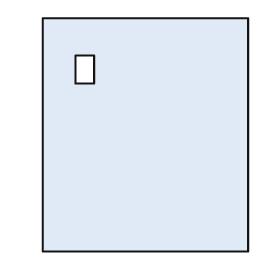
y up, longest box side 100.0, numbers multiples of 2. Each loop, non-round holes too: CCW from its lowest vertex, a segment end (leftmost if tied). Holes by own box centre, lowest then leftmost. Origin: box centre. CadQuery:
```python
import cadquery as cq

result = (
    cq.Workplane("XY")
    .moveTo(-44.0, -50.0)
    .lineTo(44.0, -50.0)
    .lineTo(44.0, 50.0)
    .lineTo(-44.0, 50.0)
    .close()
    .moveTo(-30.0, 22.0)
    .lineTo(-22.0, 22.0)
    .lineTo(-22.0, 34.0)
    .lineTo(-30.0, 34.0)
    .close()
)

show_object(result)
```